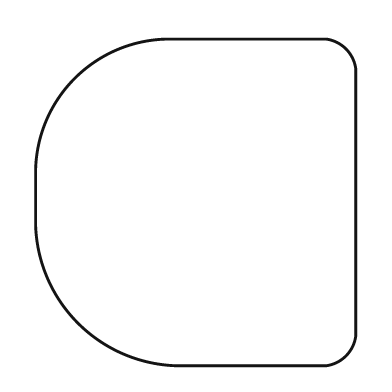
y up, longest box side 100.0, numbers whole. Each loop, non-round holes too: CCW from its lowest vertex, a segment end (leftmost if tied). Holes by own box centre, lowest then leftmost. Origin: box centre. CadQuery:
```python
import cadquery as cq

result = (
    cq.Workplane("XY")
    .moveTo(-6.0, -50.0)
    .lineTo(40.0, -50.0)
    .threePointArc((46.0, -47.0), (49.0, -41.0))
    .lineTo(49.0, 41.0)
    .threePointArc((46.0, 47.0), (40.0, 50.0))
    .lineTo(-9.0, 50.0)
    .threePointArc((-37.0, 38.0), (-49.0, 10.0))
    .lineTo(-49.0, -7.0)
    .threePointArc((-36.0, -37.0), (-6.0, -50.0))
    .close()
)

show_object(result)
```